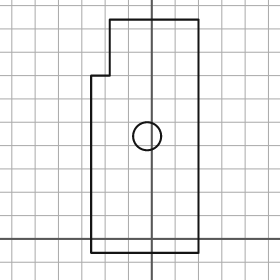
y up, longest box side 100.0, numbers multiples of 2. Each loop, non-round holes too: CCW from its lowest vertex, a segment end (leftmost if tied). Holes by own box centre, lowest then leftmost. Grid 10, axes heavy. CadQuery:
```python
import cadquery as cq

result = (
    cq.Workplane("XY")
    .moveTo(-26.0, -6.0)
    .lineTo(20.0, -6.0)
    .lineTo(20.0, 94.0)
    .lineTo(-18.0, 94.0)
    .lineTo(-18.0, 70.0)
    .lineTo(-26.0, 70.0)
    .close()
    .moveTo(-2.0, 44.0)
    .circle(6.0)
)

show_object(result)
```